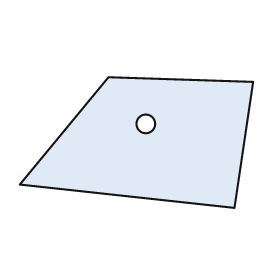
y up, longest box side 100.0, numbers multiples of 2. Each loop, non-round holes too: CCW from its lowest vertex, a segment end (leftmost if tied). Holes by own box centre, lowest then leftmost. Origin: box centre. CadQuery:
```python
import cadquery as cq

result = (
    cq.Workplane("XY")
    .moveTo(42.0, -28.0)
    .lineTo(50.0, 26.0)
    .lineTo(-12.0, 28.0)
    .lineTo(-50.0, -18.0)
    .close()
    .moveTo(4.0, 8.0)
    .circle(4.0)
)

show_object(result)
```